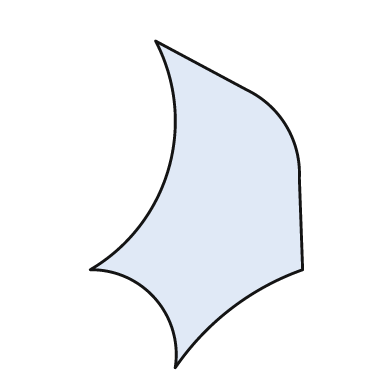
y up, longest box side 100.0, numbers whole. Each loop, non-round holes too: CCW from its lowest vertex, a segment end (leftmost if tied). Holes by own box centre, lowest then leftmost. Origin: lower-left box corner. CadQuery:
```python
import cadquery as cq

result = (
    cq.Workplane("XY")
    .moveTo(26.0, 0.0)
    .threePointArc((43.0, 18.0), (65.0, 30.0))
    .lineTo(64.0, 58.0)
    .threePointArc((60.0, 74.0), (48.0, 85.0))
    .lineTo(20.0, 100.0)
    .threePointArc((24.0, 61.0), (0.0, 30.0))
    .threePointArc((20.0, 21.0), (26.0, 0.0))
    .close()
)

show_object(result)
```